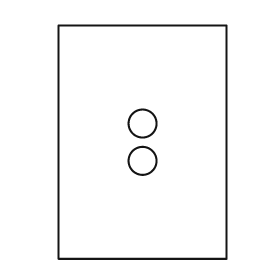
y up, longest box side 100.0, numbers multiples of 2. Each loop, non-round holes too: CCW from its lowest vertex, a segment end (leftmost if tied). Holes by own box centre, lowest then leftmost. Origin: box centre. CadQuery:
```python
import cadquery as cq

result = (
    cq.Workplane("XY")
    .moveTo(-36.0, -50.0)
    .lineTo(36.0, -50.0)
    .lineTo(36.0, 50.0)
    .lineTo(-36.0, 50.0)
    .close()
    .moveTo(0.0, -8.0)
    .circle(6.0)
    .moveTo(0.0, 8.0)
    .circle(6.0)
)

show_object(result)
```